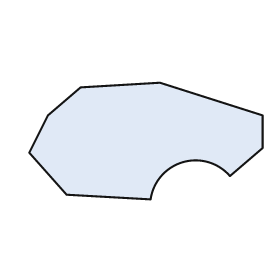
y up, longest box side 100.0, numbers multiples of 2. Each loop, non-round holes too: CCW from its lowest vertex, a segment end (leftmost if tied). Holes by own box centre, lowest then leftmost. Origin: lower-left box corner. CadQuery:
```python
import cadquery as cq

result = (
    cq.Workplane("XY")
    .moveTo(52.0, 0.0)
    .threePointArc((66.0, 16.0), (86.0, 10.0))
    .lineTo(100.0, 22.0)
    .lineTo(100.0, 36.0)
    .lineTo(56.0, 50.0)
    .lineTo(22.0, 48.0)
    .lineTo(8.0, 36.0)
    .lineTo(0.0, 20.0)
    .lineTo(16.0, 2.0)
    .close()
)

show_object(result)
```